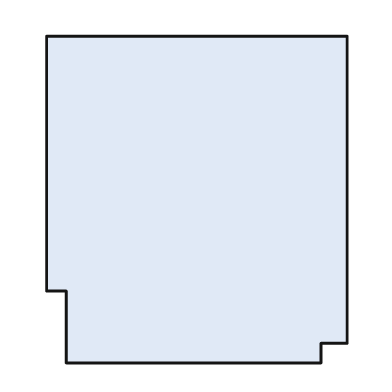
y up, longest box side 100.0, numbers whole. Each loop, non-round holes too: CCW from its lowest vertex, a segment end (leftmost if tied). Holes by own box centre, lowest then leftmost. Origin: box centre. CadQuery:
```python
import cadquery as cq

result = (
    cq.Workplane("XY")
    .moveTo(-40.0, -50.0)
    .lineTo(38.0, -50.0)
    .lineTo(38.0, -44.0)
    .lineTo(46.0, -44.0)
    .lineTo(46.0, 50.0)
    .lineTo(-46.0, 50.0)
    .lineTo(-46.0, -28.0)
    .lineTo(-40.0, -28.0)
    .close()
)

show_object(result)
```